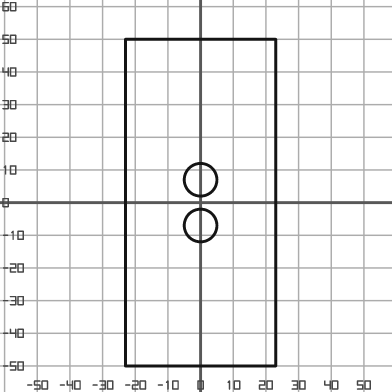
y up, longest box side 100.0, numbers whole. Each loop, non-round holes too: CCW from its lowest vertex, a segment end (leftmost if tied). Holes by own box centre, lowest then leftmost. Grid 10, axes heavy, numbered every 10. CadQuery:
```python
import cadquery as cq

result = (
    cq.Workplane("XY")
    .moveTo(-23.0, -50.0)
    .lineTo(23.0, -50.0)
    .lineTo(23.0, 50.0)
    .lineTo(-23.0, 50.0)
    .close()
    .moveTo(0.0, -7.0)
    .circle(5.0)
    .moveTo(0.0, 7.0)
    .circle(5.0)
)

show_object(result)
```